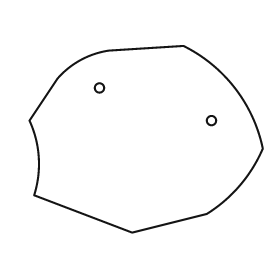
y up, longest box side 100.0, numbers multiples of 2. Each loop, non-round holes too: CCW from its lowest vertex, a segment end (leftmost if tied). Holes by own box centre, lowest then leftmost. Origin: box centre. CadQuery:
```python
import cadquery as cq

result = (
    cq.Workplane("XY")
    .moveTo(-6.0, -40.0)
    .lineTo(26.0, -32.0)
    .threePointArc((40.0, -20.0), (50.0, -4.0))
    .threePointArc((38.0, 22.0), (16.0, 40.0))
    .lineTo(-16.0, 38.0)
    .threePointArc((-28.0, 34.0), (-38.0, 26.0))
    .lineTo(-50.0, 8.0)
    .threePointArc((-46.0, -8.0), (-48.0, -24.0))
    .close()
    .moveTo(28.0, 8.0)
    .circle(2.0)
    .moveTo(-20.0, 22.0)
    .circle(2.0)
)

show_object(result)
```